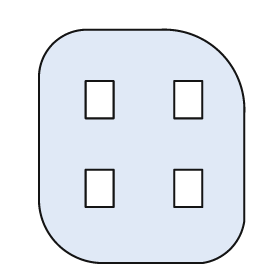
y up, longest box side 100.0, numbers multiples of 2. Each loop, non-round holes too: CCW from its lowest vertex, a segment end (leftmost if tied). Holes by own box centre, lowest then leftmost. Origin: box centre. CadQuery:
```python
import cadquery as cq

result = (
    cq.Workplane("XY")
    .moveTo(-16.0, -50.0)
    .lineTo(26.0, -50.0)
    .threePointArc((38.0, -44.0), (44.0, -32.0))
    .lineTo(44.0, 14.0)
    .threePointArc((34.0, 40.0), (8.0, 50.0))
    .lineTo(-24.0, 50.0)
    .threePointArc((-38.0, 44.0), (-44.0, 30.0))
    .lineTo(-44.0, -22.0)
    .threePointArc((-36.0, -42.0), (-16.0, -50.0))
    .close()
    .moveTo(-24.0, -26.0)
    .lineTo(-12.0, -26.0)
    .lineTo(-12.0, -10.0)
    .lineTo(-24.0, -10.0)
    .close()
    .moveTo(14.0, -26.0)
    .lineTo(26.0, -26.0)
    .lineTo(26.0, -10.0)
    .lineTo(14.0, -10.0)
    .close()
    .moveTo(-24.0, 12.0)
    .lineTo(-12.0, 12.0)
    .lineTo(-12.0, 28.0)
    .lineTo(-24.0, 28.0)
    .close()
    .moveTo(14.0, 12.0)
    .lineTo(26.0, 12.0)
    .lineTo(26.0, 28.0)
    .lineTo(14.0, 28.0)
    .close()
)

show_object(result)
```